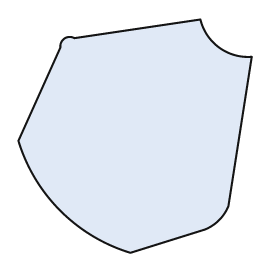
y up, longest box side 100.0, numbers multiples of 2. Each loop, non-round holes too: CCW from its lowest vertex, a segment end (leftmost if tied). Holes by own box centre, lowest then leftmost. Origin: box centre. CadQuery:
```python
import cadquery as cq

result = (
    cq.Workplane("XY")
    .moveTo(-2.0, -50.0)
    .lineTo(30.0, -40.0)
    .threePointArc((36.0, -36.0), (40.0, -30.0))
    .lineTo(50.0, 34.0)
    .threePointArc((36.0, 38.0), (28.0, 50.0))
    .lineTo(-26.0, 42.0)
    .threePointArc((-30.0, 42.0), (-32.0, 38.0))
    .lineTo(-50.0, -2.0)
    .threePointArc((-32.0, -32.0), (-2.0, -50.0))
    .close()
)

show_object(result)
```